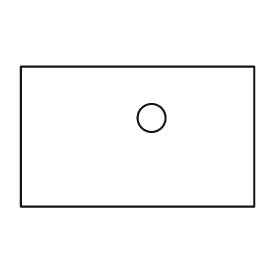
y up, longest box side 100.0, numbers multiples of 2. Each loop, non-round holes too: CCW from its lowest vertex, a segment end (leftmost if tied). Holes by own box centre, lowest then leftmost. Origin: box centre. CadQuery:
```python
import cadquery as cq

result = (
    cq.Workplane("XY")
    .moveTo(-50.0, -30.0)
    .lineTo(50.0, -30.0)
    .lineTo(50.0, 30.0)
    .lineTo(-50.0, 30.0)
    .close()
    .moveTo(6.0, 8.0)
    .circle(6.0)
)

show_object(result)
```